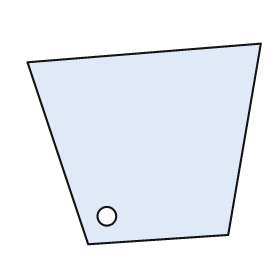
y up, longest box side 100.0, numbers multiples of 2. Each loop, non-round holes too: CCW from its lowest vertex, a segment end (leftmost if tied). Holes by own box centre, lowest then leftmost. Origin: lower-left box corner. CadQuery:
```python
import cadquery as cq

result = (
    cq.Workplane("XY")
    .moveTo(26.0, 0.0)
    .lineTo(86.0, 4.0)
    .lineTo(100.0, 86.0)
    .lineTo(0.0, 78.0)
    .close()
    .moveTo(34.0, 12.0)
    .circle(4.0)
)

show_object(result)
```